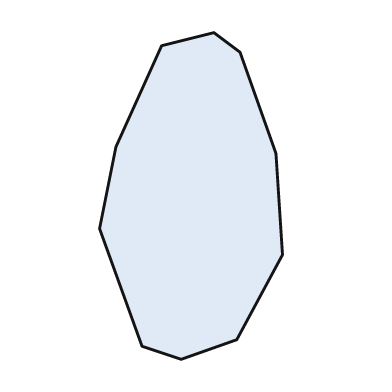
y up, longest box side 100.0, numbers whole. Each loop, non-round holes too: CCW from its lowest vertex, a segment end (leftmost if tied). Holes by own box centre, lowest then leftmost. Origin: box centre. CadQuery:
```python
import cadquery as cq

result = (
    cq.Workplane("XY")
    .moveTo(-3.0, -50.0)
    .lineTo(14.0, -44.0)
    .lineTo(28.0, -18.0)
    .lineTo(26.0, 13.0)
    .lineTo(15.0, 44.0)
    .lineTo(7.0, 50.0)
    .lineTo(-9.0, 46.0)
    .lineTo(-23.0, 15.0)
    .lineTo(-28.0, -10.0)
    .lineTo(-15.0, -46.0)
    .close()
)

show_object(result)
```